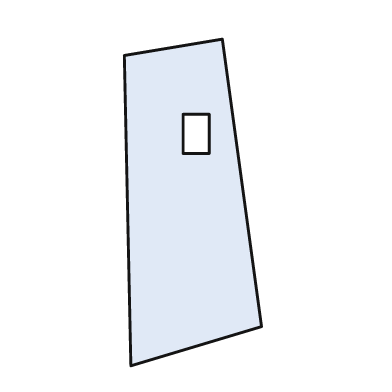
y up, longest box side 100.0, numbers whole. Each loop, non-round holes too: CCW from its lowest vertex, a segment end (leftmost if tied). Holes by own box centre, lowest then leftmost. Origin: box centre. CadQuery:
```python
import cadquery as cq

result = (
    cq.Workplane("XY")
    .moveTo(-19.0, -50.0)
    .lineTo(21.0, -38.0)
    .lineTo(9.0, 50.0)
    .lineTo(-21.0, 45.0)
    .close()
    .moveTo(-3.0, 15.0)
    .lineTo(5.0, 15.0)
    .lineTo(5.0, 27.0)
    .lineTo(-3.0, 27.0)
    .close()
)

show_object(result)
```